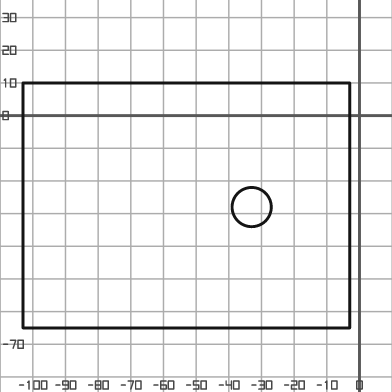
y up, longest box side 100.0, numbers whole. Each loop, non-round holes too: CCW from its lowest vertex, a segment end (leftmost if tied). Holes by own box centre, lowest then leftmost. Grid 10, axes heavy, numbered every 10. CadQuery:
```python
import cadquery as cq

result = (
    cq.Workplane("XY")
    .moveTo(-103.0, -65.0)
    .lineTo(-3.0, -65.0)
    .lineTo(-3.0, 10.0)
    .lineTo(-103.0, 10.0)
    .close()
    .moveTo(-33.0, -28.0)
    .circle(6.0)
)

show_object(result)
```